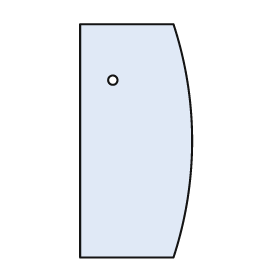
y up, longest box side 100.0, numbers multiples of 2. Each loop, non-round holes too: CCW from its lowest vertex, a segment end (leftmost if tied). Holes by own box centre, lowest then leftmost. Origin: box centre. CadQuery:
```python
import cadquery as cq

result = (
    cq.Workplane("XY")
    .moveTo(-24.0, -50.0)
    .lineTo(16.0, -50.0)
    .threePointArc((24.0, 0.0), (16.0, 50.0))
    .lineTo(-24.0, 50.0)
    .close()
    .moveTo(-10.0, 26.0)
    .circle(2.0)
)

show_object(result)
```